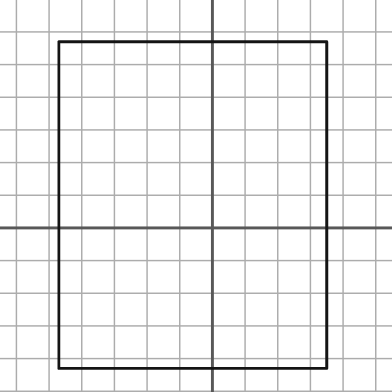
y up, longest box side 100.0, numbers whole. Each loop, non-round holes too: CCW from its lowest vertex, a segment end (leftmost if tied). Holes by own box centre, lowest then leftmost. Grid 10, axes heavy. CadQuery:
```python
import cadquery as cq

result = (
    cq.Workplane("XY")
    .moveTo(-47.0, -43.0)
    .lineTo(35.0, -43.0)
    .lineTo(35.0, 57.0)
    .lineTo(-47.0, 57.0)
    .close()
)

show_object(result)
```